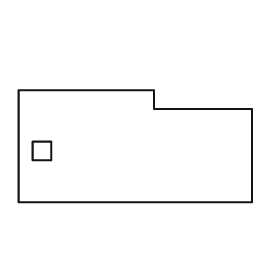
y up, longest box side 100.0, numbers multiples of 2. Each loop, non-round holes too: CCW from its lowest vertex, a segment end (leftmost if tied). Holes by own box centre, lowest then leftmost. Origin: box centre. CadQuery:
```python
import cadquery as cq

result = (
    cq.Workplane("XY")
    .moveTo(-50.0, -24.0)
    .lineTo(50.0, -24.0)
    .lineTo(50.0, 16.0)
    .lineTo(8.0, 16.0)
    .lineTo(8.0, 24.0)
    .lineTo(-50.0, 24.0)
    .close()
    .moveTo(-44.0, -6.0)
    .lineTo(-36.0, -6.0)
    .lineTo(-36.0, 2.0)
    .lineTo(-44.0, 2.0)
    .close()
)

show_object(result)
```